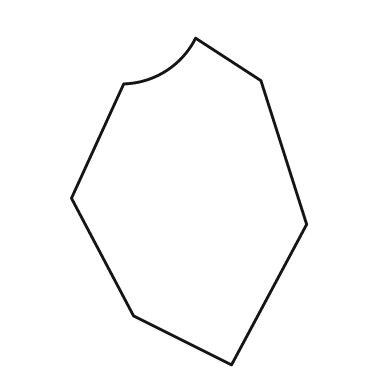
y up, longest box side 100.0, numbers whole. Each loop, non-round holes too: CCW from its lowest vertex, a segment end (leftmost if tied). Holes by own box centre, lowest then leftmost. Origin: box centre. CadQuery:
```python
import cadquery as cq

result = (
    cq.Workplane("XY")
    .moveTo(13.0, -50.0)
    .lineTo(36.0, -7.0)
    .lineTo(22.0, 37.0)
    .lineTo(2.0, 50.0)
    .threePointArc((-7.0, 40.0), (-20.0, 36.0))
    .lineTo(-36.0, 1.0)
    .lineTo(-17.0, -35.0)
    .close()
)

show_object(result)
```